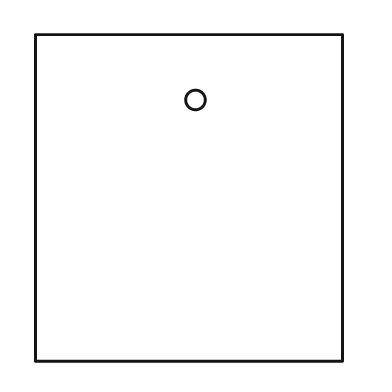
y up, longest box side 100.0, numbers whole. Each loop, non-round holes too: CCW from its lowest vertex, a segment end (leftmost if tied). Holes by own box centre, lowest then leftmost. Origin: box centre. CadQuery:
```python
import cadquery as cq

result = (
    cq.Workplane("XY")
    .moveTo(-47.0, -50.0)
    .lineTo(47.0, -50.0)
    .lineTo(47.0, 50.0)
    .lineTo(-47.0, 50.0)
    .close()
    .moveTo(2.0, 30.0)
    .circle(3.0)
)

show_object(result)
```